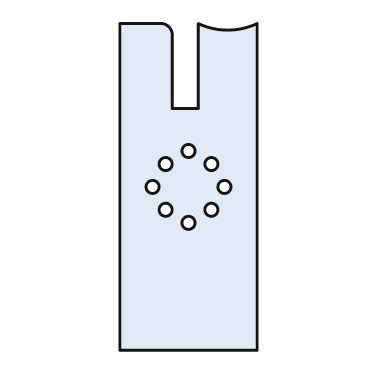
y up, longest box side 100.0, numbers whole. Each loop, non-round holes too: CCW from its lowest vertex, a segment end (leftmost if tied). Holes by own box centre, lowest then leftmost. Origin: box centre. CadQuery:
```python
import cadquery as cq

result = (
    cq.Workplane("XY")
    .moveTo(-21.0, -50.0)
    .lineTo(21.0, -50.0)
    .lineTo(21.0, 50.0)
    .threePointArc((12.0, 48.0), (3.0, 50.0))
    .lineTo(3.0, 24.0)
    .lineTo(-5.0, 24.0)
    .lineTo(-5.0, 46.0)
    .threePointArc((-6.0, 49.0), (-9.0, 50.0))
    .lineTo(-21.0, 50.0)
    .close()
    .moveTo(0.0, -11.0)
    .circle(2.0)
    .moveTo(-7.0, -7.0)
    .circle(2.0)
    .moveTo(7.0, -7.0)
    .circle(2.0)
    .moveTo(-11.0, 0.0)
    .circle(2.0)
    .moveTo(11.0, 0.0)
    .circle(2.0)
    .moveTo(-7.0, 7.0)
    .circle(2.0)
    .moveTo(7.0, 7.0)
    .circle(2.0)
    .moveTo(0.0, 11.0)
    .circle(2.0)
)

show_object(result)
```